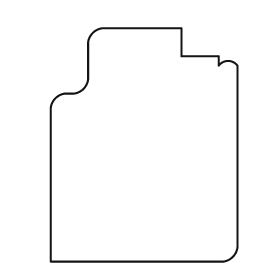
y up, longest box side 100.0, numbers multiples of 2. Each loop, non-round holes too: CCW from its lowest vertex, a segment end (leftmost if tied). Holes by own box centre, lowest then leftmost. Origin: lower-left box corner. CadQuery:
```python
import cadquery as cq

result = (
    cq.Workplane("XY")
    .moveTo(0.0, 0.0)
    .lineTo(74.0, 0.0)
    .threePointArc((78.0, 2.0), (80.0, 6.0))
    .lineTo(80.0, 84.0)
    .threePointArc((76.0, 86.0), (72.0, 84.0))
    .lineTo(72.0, 88.0)
    .lineTo(56.0, 88.0)
    .lineTo(56.0, 100.0)
    .lineTo(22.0, 100.0)
    .threePointArc((18.0, 98.0), (16.0, 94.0))
    .lineTo(16.0, 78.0)
    .threePointArc((14.0, 74.0), (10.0, 72.0))
    .lineTo(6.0, 72.0)
    .threePointArc((2.0, 70.0), (0.0, 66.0))
    .close()
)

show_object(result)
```